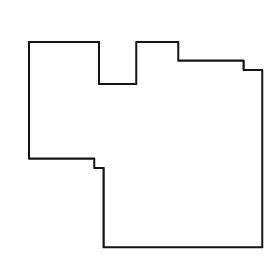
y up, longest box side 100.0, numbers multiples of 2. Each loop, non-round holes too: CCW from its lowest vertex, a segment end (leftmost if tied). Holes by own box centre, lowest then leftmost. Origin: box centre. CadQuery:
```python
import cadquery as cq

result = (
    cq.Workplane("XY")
    .moveTo(-18.0, -44.0)
    .lineTo(50.0, -44.0)
    .lineTo(50.0, 32.0)
    .lineTo(42.0, 32.0)
    .lineTo(42.0, 36.0)
    .lineTo(14.0, 36.0)
    .lineTo(14.0, 44.0)
    .lineTo(-4.0, 44.0)
    .lineTo(-4.0, 26.0)
    .lineTo(-20.0, 26.0)
    .lineTo(-20.0, 44.0)
    .lineTo(-50.0, 44.0)
    .lineTo(-50.0, -6.0)
    .lineTo(-22.0, -6.0)
    .lineTo(-22.0, -10.0)
    .lineTo(-18.0, -10.0)
    .close()
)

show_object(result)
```